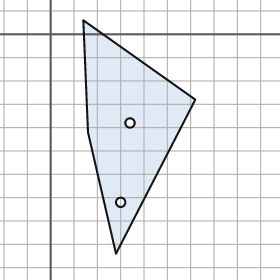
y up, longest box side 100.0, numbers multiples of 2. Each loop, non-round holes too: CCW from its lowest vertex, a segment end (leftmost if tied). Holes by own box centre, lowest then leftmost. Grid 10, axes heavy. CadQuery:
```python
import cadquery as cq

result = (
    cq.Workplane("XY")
    .moveTo(28.0, -94.0)
    .lineTo(62.0, -28.0)
    .lineTo(14.0, 6.0)
    .lineTo(16.0, -42.0)
    .close()
    .moveTo(30.0, -72.0)
    .circle(2.0)
    .moveTo(34.0, -38.0)
    .circle(2.0)
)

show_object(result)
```